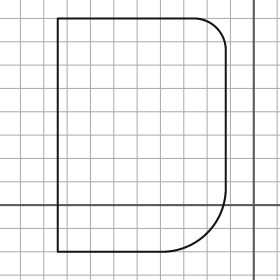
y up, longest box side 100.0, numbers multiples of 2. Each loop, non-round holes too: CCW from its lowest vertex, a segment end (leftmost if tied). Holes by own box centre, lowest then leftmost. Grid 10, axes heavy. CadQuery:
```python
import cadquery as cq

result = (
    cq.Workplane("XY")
    .moveTo(-84.0, -20.0)
    .lineTo(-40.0, -20.0)
    .threePointArc((-20.0, -12.0), (-12.0, 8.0))
    .lineTo(-12.0, 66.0)
    .threePointArc((-16.0, 76.0), (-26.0, 80.0))
    .lineTo(-84.0, 80.0)
    .close()
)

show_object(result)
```